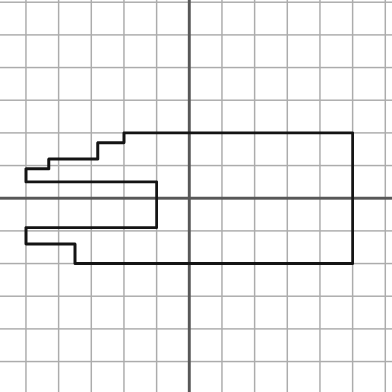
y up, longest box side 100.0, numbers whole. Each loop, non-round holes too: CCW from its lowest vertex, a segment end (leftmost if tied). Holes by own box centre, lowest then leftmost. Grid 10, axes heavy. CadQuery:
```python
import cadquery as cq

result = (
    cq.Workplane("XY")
    .moveTo(-35.0, -20.0)
    .lineTo(50.0, -20.0)
    .lineTo(50.0, 20.0)
    .lineTo(-20.0, 20.0)
    .lineTo(-20.0, 17.0)
    .lineTo(-28.0, 17.0)
    .lineTo(-28.0, 12.0)
    .lineTo(-43.0, 12.0)
    .lineTo(-43.0, 9.0)
    .lineTo(-50.0, 9.0)
    .lineTo(-50.0, 5.0)
    .lineTo(-10.0, 5.0)
    .lineTo(-10.0, -9.0)
    .lineTo(-50.0, -9.0)
    .lineTo(-50.0, -14.0)
    .lineTo(-35.0, -14.0)
    .close()
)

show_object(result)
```